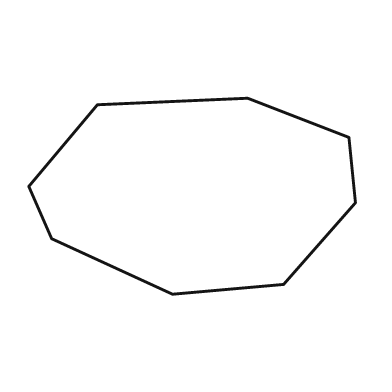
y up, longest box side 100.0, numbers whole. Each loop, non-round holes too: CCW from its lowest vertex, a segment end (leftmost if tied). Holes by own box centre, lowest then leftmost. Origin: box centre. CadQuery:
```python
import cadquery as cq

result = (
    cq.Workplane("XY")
    .moveTo(-6.0, -30.0)
    .lineTo(28.0, -27.0)
    .lineTo(50.0, -2.0)
    .lineTo(48.0, 18.0)
    .lineTo(17.0, 30.0)
    .lineTo(-29.0, 28.0)
    .lineTo(-50.0, 3.0)
    .lineTo(-43.0, -13.0)
    .close()
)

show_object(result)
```